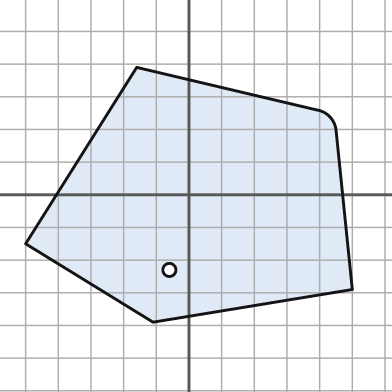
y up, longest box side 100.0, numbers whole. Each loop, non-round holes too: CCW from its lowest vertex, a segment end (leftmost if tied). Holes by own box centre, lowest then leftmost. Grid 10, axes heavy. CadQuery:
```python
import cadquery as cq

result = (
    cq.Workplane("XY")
    .moveTo(-11.0, -39.0)
    .lineTo(50.0, -29.0)
    .lineTo(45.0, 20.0)
    .threePointArc((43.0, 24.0), (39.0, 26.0))
    .lineTo(-16.0, 39.0)
    .lineTo(-50.0, -15.0)
    .close()
    .moveTo(-6.0, -23.0)
    .circle(2.0)
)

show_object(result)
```